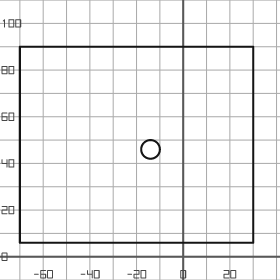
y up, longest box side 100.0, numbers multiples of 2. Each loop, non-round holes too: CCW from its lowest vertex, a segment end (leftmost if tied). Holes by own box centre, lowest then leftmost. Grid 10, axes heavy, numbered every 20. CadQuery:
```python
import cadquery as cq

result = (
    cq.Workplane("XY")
    .moveTo(-70.0, 6.0)
    .lineTo(30.0, 6.0)
    .lineTo(30.0, 90.0)
    .lineTo(-70.0, 90.0)
    .close()
    .moveTo(-14.0, 46.0)
    .circle(4.0)
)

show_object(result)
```